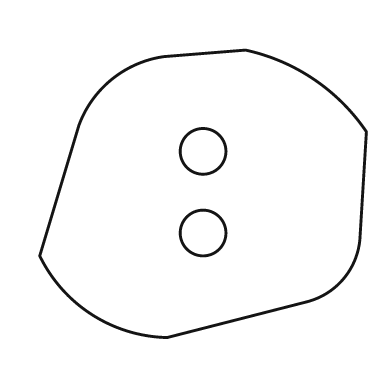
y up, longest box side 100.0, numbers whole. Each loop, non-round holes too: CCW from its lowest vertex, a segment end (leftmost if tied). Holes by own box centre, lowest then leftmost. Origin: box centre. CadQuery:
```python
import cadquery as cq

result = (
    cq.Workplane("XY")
    .moveTo(-11.0, -44.0)
    .lineTo(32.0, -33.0)
    .threePointArc((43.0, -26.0), (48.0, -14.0))
    .lineTo(50.0, 19.0)
    .threePointArc((34.0, 35.0), (13.0, 44.0))
    .lineTo(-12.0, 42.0)
    .threePointArc((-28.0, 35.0), (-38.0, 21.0))
    .lineTo(-50.0, -19.0)
    .threePointArc((-34.0, -37.0), (-11.0, -44.0))
    .close()
    .moveTo(0.0, -12.0)
    .circle(7.0)
    .moveTo(0.0, 13.0)
    .circle(7.0)
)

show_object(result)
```